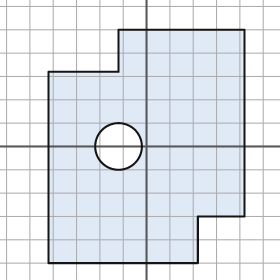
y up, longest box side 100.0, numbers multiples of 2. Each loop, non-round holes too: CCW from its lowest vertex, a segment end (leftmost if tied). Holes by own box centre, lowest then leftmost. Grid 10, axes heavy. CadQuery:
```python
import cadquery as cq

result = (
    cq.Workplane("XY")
    .moveTo(-42.0, -50.0)
    .lineTo(22.0, -50.0)
    .lineTo(22.0, -30.0)
    .lineTo(42.0, -30.0)
    .lineTo(42.0, 50.0)
    .lineTo(-12.0, 50.0)
    .lineTo(-12.0, 32.0)
    .lineTo(-42.0, 32.0)
    .close()
    .moveTo(-12.0, 0.0)
    .circle(10.0)
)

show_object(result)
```